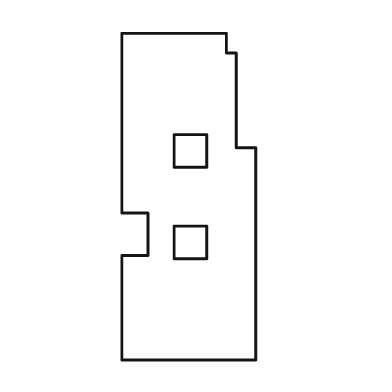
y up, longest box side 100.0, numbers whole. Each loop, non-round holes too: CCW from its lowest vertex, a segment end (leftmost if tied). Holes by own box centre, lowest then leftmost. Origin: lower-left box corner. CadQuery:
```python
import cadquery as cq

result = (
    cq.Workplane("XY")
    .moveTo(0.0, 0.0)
    .lineTo(41.0, 0.0)
    .lineTo(41.0, 65.0)
    .lineTo(35.0, 65.0)
    .lineTo(35.0, 94.0)
    .lineTo(32.0, 94.0)
    .lineTo(32.0, 100.0)
    .lineTo(0.0, 100.0)
    .lineTo(0.0, 45.0)
    .lineTo(8.0, 45.0)
    .lineTo(8.0, 32.0)
    .lineTo(0.0, 32.0)
    .close()
    .moveTo(16.0, 31.0)
    .lineTo(26.0, 31.0)
    .lineTo(26.0, 41.0)
    .lineTo(16.0, 41.0)
    .close()
    .moveTo(16.0, 59.0)
    .lineTo(26.0, 59.0)
    .lineTo(26.0, 69.0)
    .lineTo(16.0, 69.0)
    .close()
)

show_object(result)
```